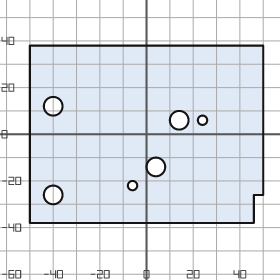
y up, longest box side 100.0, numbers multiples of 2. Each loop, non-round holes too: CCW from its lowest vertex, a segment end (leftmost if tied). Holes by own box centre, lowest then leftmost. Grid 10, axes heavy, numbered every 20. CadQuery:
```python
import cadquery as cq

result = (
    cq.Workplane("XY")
    .moveTo(-50.0, -38.0)
    .lineTo(46.0, -38.0)
    .lineTo(46.0, -26.0)
    .lineTo(50.0, -26.0)
    .lineTo(50.0, 38.0)
    .lineTo(-50.0, 38.0)
    .close()
    .moveTo(-40.0, -26.0)
    .circle(4.0)
    .moveTo(-6.0, -22.0)
    .circle(2.0)
    .moveTo(4.0, -14.0)
    .circle(4.0)
    .moveTo(14.0, 6.0)
    .circle(4.0)
    .moveTo(24.0, 6.0)
    .circle(2.0)
    .moveTo(-40.0, 12.0)
    .circle(4.0)
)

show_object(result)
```